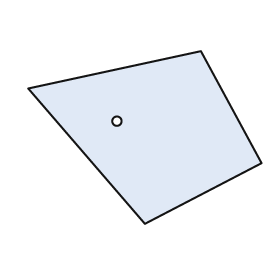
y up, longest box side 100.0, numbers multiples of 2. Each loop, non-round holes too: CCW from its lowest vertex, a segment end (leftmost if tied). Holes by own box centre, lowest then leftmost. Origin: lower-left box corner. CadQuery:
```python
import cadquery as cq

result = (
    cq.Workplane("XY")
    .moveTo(50.0, 0.0)
    .lineTo(100.0, 26.0)
    .lineTo(74.0, 74.0)
    .lineTo(0.0, 58.0)
    .close()
    .moveTo(38.0, 44.0)
    .circle(2.0)
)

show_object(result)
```